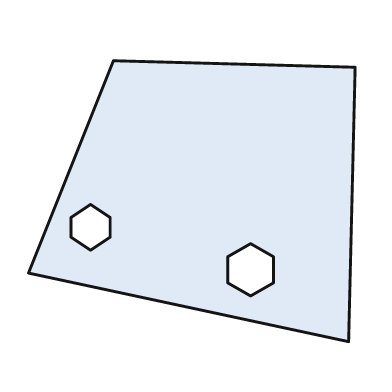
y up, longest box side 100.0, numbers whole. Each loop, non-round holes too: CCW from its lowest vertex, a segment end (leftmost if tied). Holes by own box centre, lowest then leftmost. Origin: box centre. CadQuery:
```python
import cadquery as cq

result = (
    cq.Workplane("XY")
    .moveTo(48.0, -43.0)
    .lineTo(50.0, 41.0)
    .lineTo(-24.0, 43.0)
    .lineTo(-50.0, -22.0)
    .close()
    .moveTo(18.0, -29.0)
    .lineTo(25.0, -25.0)
    .lineTo(25.0, -17.0)
    .lineTo(18.0, -13.0)
    .lineTo(11.0, -17.0)
    .lineTo(11.0, -25.0)
    .close()
    .moveTo(-31.0, -15.0)
    .lineTo(-25.0, -11.0)
    .lineTo(-25.0, -5.0)
    .lineTo(-31.0, -1.0)
    .lineTo(-37.0, -5.0)
    .lineTo(-37.0, -11.0)
    .close()
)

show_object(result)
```